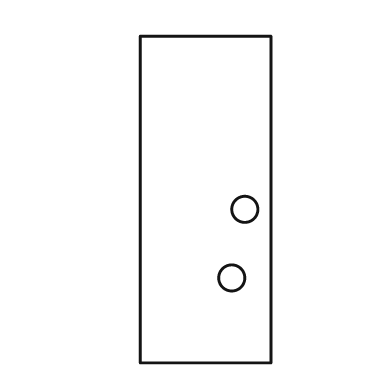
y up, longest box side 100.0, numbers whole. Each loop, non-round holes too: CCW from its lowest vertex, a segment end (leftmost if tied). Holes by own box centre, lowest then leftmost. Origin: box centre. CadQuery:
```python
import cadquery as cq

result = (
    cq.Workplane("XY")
    .moveTo(-20.0, -50.0)
    .lineTo(20.0, -50.0)
    .lineTo(20.0, 50.0)
    .lineTo(-20.0, 50.0)
    .close()
    .moveTo(8.0, -24.0)
    .circle(4.0)
    .moveTo(12.0, -3.0)
    .circle(4.0)
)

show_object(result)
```